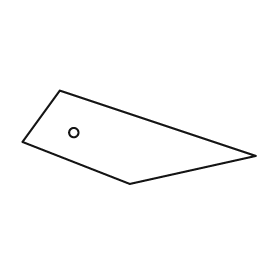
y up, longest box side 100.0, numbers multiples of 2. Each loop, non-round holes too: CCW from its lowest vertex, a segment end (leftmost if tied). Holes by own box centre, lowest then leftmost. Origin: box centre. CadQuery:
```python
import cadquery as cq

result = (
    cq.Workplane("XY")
    .moveTo(-4.0, -20.0)
    .lineTo(50.0, -8.0)
    .lineTo(-34.0, 20.0)
    .lineTo(-50.0, -2.0)
    .close()
    .moveTo(-28.0, 2.0)
    .circle(2.0)
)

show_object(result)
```